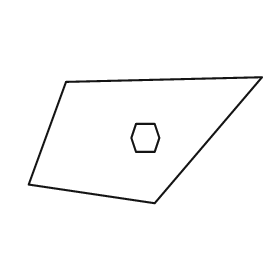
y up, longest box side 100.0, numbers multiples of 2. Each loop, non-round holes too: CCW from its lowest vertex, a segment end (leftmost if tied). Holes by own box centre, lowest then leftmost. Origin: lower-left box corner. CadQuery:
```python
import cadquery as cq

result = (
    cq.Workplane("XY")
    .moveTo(54.0, 0.0)
    .lineTo(100.0, 54.0)
    .lineTo(16.0, 52.0)
    .lineTo(0.0, 8.0)
    .close()
    .moveTo(46.0, 22.0)
    .lineTo(54.0, 22.0)
    .lineTo(56.0, 28.0)
    .lineTo(54.0, 34.0)
    .lineTo(46.0, 34.0)
    .lineTo(44.0, 28.0)
    .close()
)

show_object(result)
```